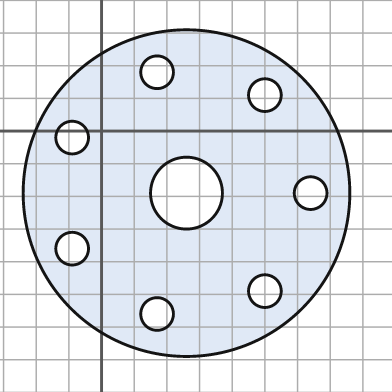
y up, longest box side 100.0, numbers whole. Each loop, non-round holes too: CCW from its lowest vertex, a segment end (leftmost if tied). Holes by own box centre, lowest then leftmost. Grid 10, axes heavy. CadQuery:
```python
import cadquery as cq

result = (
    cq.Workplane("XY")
    .moveTo(26.0, -19.0)
    .circle(50.0)
    .moveTo(17.0, -56.0)
    .circle(5.0)
    .moveTo(50.0, -49.0)
    .circle(5.0)
    .moveTo(-9.0, -36.0)
    .circle(5.0)
    .moveTo(26.0, -19.0)
    .circle(11.0)
    .moveTo(64.0, -19.0)
    .circle(5.0)
    .moveTo(-9.0, -2.0)
    .circle(5.0)
    .moveTo(50.0, 11.0)
    .circle(5.0)
    .moveTo(17.0, 18.0)
    .circle(5.0)
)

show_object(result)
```